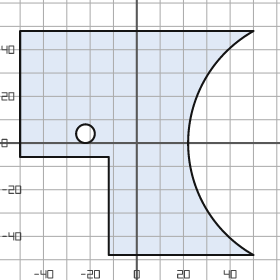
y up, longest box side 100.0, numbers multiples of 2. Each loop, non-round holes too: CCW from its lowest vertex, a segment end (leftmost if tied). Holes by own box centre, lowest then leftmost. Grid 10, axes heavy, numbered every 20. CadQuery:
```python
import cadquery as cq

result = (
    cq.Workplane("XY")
    .moveTo(-12.0, -48.0)
    .lineTo(50.0, -48.0)
    .threePointArc((22.0, 0.0), (50.0, 48.0))
    .lineTo(-50.0, 48.0)
    .lineTo(-50.0, -6.0)
    .lineTo(-12.0, -6.0)
    .close()
    .moveTo(-22.0, 4.0)
    .circle(4.0)
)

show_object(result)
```